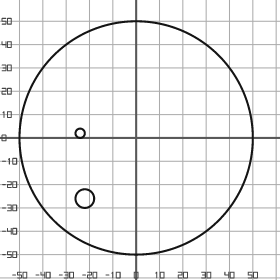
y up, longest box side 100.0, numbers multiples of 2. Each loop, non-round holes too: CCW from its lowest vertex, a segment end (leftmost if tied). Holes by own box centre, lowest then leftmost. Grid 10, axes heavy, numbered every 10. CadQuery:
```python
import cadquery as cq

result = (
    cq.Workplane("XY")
    .moveTo(0.0, 0.0)
    .circle(50.0)
    .moveTo(-22.0, -26.0)
    .circle(4.0)
    .moveTo(-24.0, 2.0)
    .circle(2.0)
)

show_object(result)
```